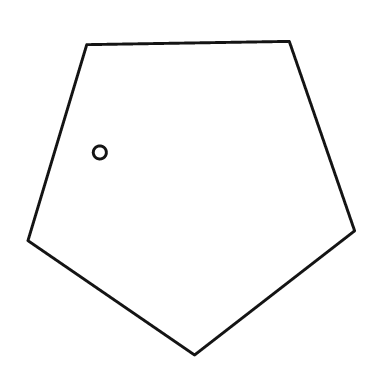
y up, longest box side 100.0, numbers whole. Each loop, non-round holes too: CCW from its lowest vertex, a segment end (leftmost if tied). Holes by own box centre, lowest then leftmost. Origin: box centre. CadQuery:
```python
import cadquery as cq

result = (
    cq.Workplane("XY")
    .moveTo(1.0, -48.0)
    .lineTo(50.0, -10.0)
    .lineTo(30.0, 48.0)
    .lineTo(-32.0, 47.0)
    .lineTo(-50.0, -13.0)
    .close()
    .moveTo(-28.0, 14.0)
    .circle(2.0)
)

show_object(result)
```